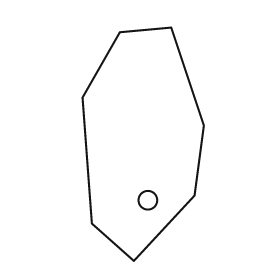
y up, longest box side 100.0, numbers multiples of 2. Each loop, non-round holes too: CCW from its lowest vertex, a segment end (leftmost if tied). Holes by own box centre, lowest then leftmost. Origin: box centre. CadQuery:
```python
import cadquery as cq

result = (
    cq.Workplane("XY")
    .moveTo(-4.0, -50.0)
    .lineTo(22.0, -22.0)
    .lineTo(26.0, 8.0)
    .lineTo(12.0, 50.0)
    .lineTo(-10.0, 48.0)
    .lineTo(-26.0, 20.0)
    .lineTo(-22.0, -34.0)
    .close()
    .moveTo(2.0, -24.0)
    .circle(4.0)
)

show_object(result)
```